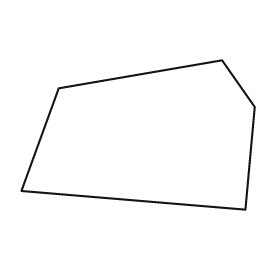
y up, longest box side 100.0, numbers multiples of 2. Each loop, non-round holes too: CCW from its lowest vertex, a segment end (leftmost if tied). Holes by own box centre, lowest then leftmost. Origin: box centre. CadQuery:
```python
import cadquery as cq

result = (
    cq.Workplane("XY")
    .moveTo(46.0, -32.0)
    .lineTo(50.0, 12.0)
    .lineTo(36.0, 32.0)
    .lineTo(-34.0, 20.0)
    .lineTo(-50.0, -24.0)
    .close()
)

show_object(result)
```